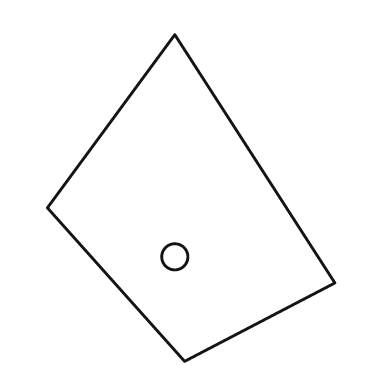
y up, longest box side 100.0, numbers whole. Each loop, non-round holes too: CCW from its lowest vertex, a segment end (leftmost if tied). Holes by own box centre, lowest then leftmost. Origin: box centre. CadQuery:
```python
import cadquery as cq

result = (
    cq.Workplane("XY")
    .moveTo(-2.0, -50.0)
    .lineTo(44.0, -26.0)
    .lineTo(-5.0, 50.0)
    .lineTo(-44.0, -3.0)
    .close()
    .moveTo(-5.0, -18.0)
    .circle(4.0)
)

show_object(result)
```